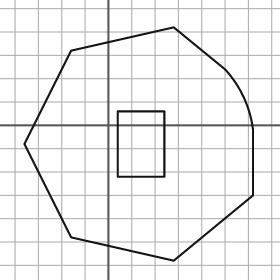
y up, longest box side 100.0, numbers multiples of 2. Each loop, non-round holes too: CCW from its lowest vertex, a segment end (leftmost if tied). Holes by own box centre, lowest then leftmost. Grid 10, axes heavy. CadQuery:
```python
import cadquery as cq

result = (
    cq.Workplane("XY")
    .moveTo(28.0, -58.0)
    .lineTo(62.0, -30.0)
    .lineTo(62.0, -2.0)
    .threePointArc((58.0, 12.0), (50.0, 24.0))
    .lineTo(28.0, 42.0)
    .lineTo(-16.0, 32.0)
    .lineTo(-36.0, -8.0)
    .lineTo(-16.0, -48.0)
    .close()
    .moveTo(4.0, -22.0)
    .lineTo(24.0, -22.0)
    .lineTo(24.0, 6.0)
    .lineTo(4.0, 6.0)
    .close()
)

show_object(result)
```